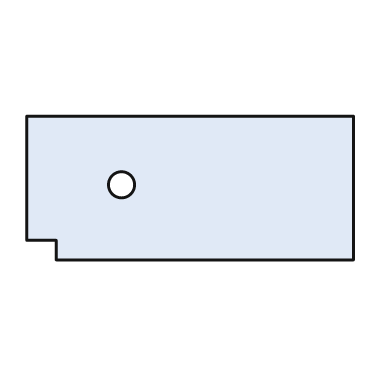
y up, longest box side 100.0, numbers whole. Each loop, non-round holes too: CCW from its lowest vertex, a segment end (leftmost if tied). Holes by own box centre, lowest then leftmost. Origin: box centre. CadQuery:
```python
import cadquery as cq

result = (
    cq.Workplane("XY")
    .moveTo(-41.0, -22.0)
    .lineTo(50.0, -22.0)
    .lineTo(50.0, 22.0)
    .lineTo(-50.0, 22.0)
    .lineTo(-50.0, -16.0)
    .lineTo(-41.0, -16.0)
    .close()
    .moveTo(-21.0, 1.0)
    .circle(4.0)
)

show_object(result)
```